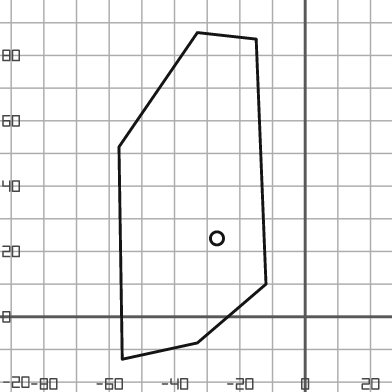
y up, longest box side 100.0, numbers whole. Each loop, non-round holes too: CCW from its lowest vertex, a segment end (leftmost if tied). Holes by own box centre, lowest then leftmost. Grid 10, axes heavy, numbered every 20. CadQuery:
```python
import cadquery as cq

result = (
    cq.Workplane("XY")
    .moveTo(-56.0, -13.0)
    .lineTo(-33.0, -8.0)
    .lineTo(-12.0, 10.0)
    .lineTo(-15.0, 85.0)
    .lineTo(-33.0, 87.0)
    .lineTo(-57.0, 52.0)
    .close()
    .moveTo(-27.0, 24.0)
    .circle(2.0)
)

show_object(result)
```